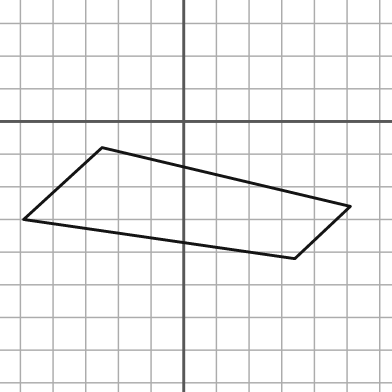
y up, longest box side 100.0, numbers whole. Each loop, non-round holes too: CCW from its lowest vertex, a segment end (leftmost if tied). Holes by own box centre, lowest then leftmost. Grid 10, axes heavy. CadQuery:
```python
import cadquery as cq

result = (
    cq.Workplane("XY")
    .moveTo(34.0, -42.0)
    .lineTo(51.0, -26.0)
    .lineTo(-25.0, -8.0)
    .lineTo(-49.0, -30.0)
    .close()
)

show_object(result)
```